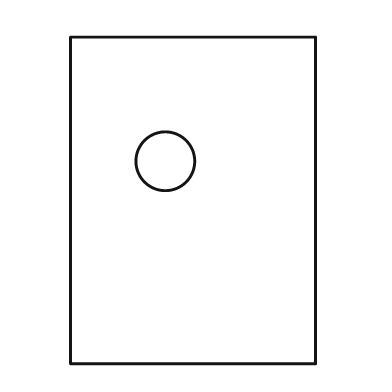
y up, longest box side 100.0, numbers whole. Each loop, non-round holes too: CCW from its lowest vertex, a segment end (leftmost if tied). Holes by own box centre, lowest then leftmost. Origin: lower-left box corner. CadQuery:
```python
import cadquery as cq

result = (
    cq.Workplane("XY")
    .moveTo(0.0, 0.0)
    .lineTo(75.0, 0.0)
    .lineTo(75.0, 100.0)
    .lineTo(0.0, 100.0)
    .close()
    .moveTo(29.0, 62.0)
    .circle(9.0)
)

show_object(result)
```